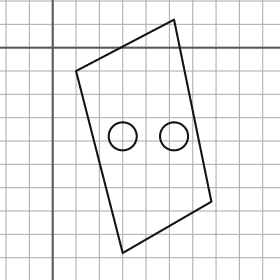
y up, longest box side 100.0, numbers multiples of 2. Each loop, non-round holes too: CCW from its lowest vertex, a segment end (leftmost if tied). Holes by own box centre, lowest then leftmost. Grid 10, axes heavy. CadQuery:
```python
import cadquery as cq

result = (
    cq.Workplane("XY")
    .moveTo(30.0, -88.0)
    .lineTo(68.0, -66.0)
    .lineTo(52.0, 12.0)
    .lineTo(10.0, -10.0)
    .close()
    .moveTo(30.0, -38.0)
    .circle(6.0)
    .moveTo(52.0, -38.0)
    .circle(6.0)
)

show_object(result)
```